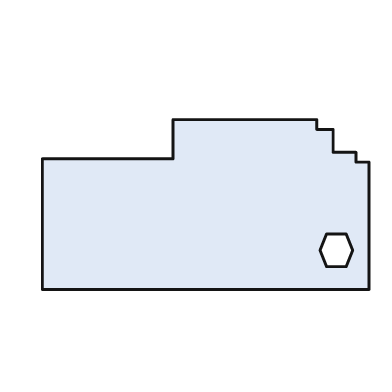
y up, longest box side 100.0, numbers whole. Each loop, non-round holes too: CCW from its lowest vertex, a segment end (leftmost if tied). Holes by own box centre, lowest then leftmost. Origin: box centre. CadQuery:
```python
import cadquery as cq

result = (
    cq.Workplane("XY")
    .moveTo(-50.0, -26.0)
    .lineTo(50.0, -26.0)
    .lineTo(50.0, 13.0)
    .lineTo(46.0, 13.0)
    .lineTo(46.0, 16.0)
    .lineTo(39.0, 16.0)
    .lineTo(39.0, 23.0)
    .lineTo(34.0, 23.0)
    .lineTo(34.0, 26.0)
    .lineTo(-10.0, 26.0)
    .lineTo(-10.0, 14.0)
    .lineTo(-50.0, 14.0)
    .close()
    .moveTo(37.0, -19.0)
    .lineTo(43.0, -19.0)
    .lineTo(45.0, -14.0)
    .lineTo(43.0, -9.0)
    .lineTo(37.0, -9.0)
    .lineTo(35.0, -14.0)
    .close()
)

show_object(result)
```